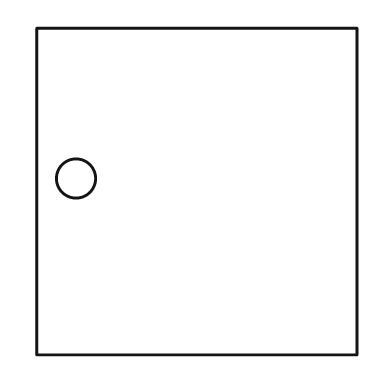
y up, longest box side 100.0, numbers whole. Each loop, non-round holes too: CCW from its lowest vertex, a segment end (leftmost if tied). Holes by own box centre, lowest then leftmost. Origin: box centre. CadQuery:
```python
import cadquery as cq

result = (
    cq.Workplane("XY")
    .moveTo(-49.0, -50.0)
    .lineTo(49.0, -50.0)
    .lineTo(49.0, 50.0)
    .lineTo(-49.0, 50.0)
    .close()
    .moveTo(-37.0, 4.0)
    .circle(6.0)
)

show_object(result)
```